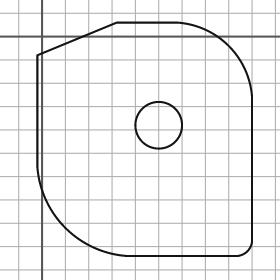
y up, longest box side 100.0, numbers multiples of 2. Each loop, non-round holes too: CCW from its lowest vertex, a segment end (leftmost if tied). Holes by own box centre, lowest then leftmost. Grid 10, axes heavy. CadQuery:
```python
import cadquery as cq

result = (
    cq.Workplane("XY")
    .moveTo(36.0, -94.0)
    .lineTo(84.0, -94.0)
    .threePointArc((88.0, -92.0), (90.0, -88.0))
    .lineTo(90.0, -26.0)
    .threePointArc((80.0, -4.0), (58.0, 6.0))
    .lineTo(32.0, 6.0)
    .lineTo(-2.0, -8.0)
    .lineTo(-2.0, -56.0)
    .threePointArc((10.0, -82.0), (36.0, -94.0))
    .close()
    .moveTo(50.0, -38.0)
    .circle(10.0)
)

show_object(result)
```